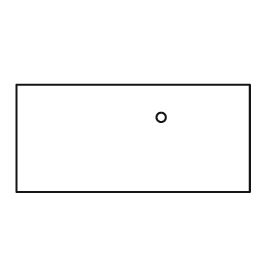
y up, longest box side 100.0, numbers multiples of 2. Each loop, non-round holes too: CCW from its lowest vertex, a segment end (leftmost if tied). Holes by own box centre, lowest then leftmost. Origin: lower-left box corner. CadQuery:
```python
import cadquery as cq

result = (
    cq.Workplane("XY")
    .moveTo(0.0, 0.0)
    .lineTo(100.0, 0.0)
    .lineTo(100.0, 46.0)
    .lineTo(0.0, 46.0)
    .close()
    .moveTo(62.0, 32.0)
    .circle(2.0)
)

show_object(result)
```